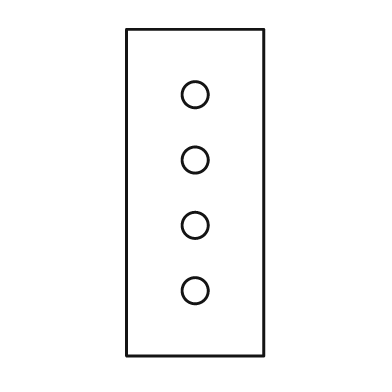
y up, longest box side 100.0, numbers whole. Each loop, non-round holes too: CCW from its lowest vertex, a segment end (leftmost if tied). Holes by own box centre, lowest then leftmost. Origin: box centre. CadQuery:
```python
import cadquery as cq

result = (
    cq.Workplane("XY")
    .moveTo(-21.0, -50.0)
    .lineTo(21.0, -50.0)
    .lineTo(21.0, 50.0)
    .lineTo(-21.0, 50.0)
    .close()
    .moveTo(0.0, -30.0)
    .circle(4.0)
    .moveTo(0.0, -10.0)
    .circle(4.0)
    .moveTo(0.0, 10.0)
    .circle(4.0)
    .moveTo(0.0, 30.0)
    .circle(4.0)
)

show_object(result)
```